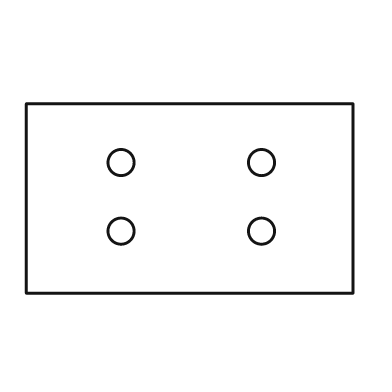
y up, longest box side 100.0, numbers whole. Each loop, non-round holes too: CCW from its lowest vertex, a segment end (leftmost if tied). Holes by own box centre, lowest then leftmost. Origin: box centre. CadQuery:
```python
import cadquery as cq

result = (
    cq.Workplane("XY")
    .moveTo(-50.0, -29.0)
    .lineTo(50.0, -29.0)
    .lineTo(50.0, 29.0)
    .lineTo(-50.0, 29.0)
    .close()
    .moveTo(-21.0, -10.0)
    .circle(4.0)
    .moveTo(22.0, -10.0)
    .circle(4.0)
    .moveTo(-21.0, 11.0)
    .circle(4.0)
    .moveTo(22.0, 11.0)
    .circle(4.0)
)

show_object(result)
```